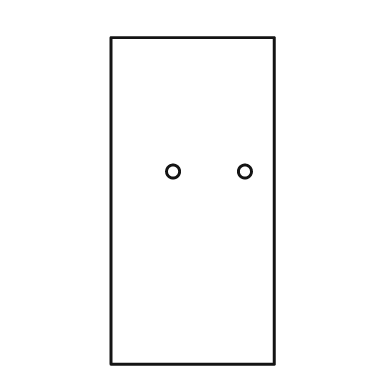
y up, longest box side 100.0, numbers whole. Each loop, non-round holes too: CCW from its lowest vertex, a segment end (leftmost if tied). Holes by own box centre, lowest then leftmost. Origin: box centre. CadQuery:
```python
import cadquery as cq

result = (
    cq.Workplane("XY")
    .moveTo(-25.0, -50.0)
    .lineTo(25.0, -50.0)
    .lineTo(25.0, 50.0)
    .lineTo(-25.0, 50.0)
    .close()
    .moveTo(-6.0, 9.0)
    .circle(2.0)
    .moveTo(16.0, 9.0)
    .circle(2.0)
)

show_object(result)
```